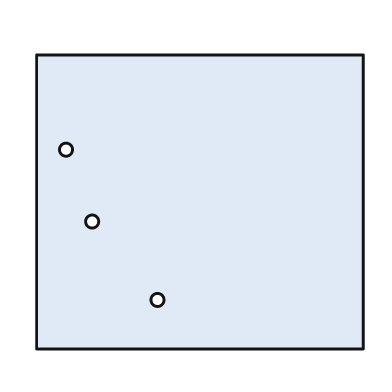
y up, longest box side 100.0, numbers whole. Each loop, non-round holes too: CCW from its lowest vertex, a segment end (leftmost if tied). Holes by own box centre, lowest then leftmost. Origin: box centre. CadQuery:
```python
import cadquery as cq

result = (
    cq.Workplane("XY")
    .moveTo(-50.0, -45.0)
    .lineTo(50.0, -45.0)
    .lineTo(50.0, 45.0)
    .lineTo(-50.0, 45.0)
    .close()
    .moveTo(-13.0, -30.0)
    .circle(2.0)
    .moveTo(-33.0, -6.0)
    .circle(2.0)
    .moveTo(-41.0, 16.0)
    .circle(2.0)
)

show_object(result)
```